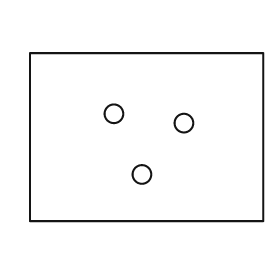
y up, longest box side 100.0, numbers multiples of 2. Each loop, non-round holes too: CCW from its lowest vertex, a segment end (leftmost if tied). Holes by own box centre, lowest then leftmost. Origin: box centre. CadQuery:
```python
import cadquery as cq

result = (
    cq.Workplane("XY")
    .moveTo(-50.0, -36.0)
    .lineTo(50.0, -36.0)
    .lineTo(50.0, 36.0)
    .lineTo(-50.0, 36.0)
    .close()
    .moveTo(-2.0, -16.0)
    .circle(4.0)
    .moveTo(16.0, 6.0)
    .circle(4.0)
    .moveTo(-14.0, 10.0)
    .circle(4.0)
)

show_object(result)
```